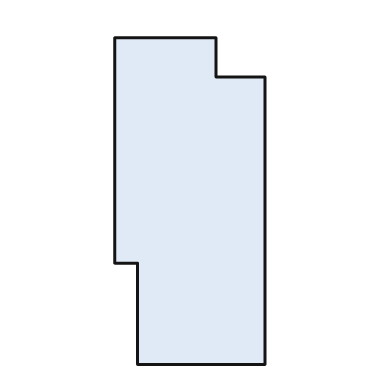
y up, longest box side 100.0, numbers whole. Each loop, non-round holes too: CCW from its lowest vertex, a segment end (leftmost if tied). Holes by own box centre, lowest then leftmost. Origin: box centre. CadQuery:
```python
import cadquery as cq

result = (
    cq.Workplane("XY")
    .moveTo(-16.0, -50.0)
    .lineTo(23.0, -50.0)
    .lineTo(23.0, 38.0)
    .lineTo(8.0, 38.0)
    .lineTo(8.0, 50.0)
    .lineTo(-23.0, 50.0)
    .lineTo(-23.0, -19.0)
    .lineTo(-16.0, -19.0)
    .close()
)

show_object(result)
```